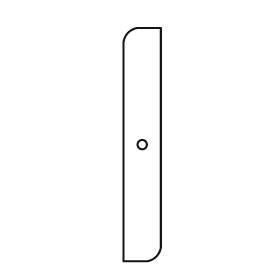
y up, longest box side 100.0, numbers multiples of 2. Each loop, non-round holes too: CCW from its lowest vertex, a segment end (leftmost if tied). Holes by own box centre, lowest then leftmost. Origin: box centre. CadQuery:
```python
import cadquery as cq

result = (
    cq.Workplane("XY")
    .moveTo(-8.0, -50.0)
    .lineTo(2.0, -50.0)
    .threePointArc((6.0, -48.0), (8.0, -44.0))
    .lineTo(8.0, 50.0)
    .lineTo(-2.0, 50.0)
    .threePointArc((-6.0, 48.0), (-8.0, 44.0))
    .close()
    .moveTo(0.0, 0.0)
    .circle(2.0)
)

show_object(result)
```